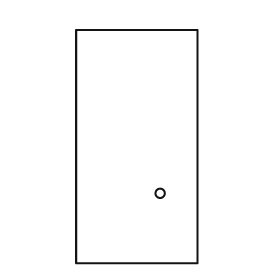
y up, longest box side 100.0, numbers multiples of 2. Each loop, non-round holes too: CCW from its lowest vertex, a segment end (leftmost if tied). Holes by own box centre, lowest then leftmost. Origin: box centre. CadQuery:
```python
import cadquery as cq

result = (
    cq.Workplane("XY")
    .moveTo(-26.0, -50.0)
    .lineTo(26.0, -50.0)
    .lineTo(26.0, 50.0)
    .lineTo(-26.0, 50.0)
    .close()
    .moveTo(10.0, -20.0)
    .circle(2.0)
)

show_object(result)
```